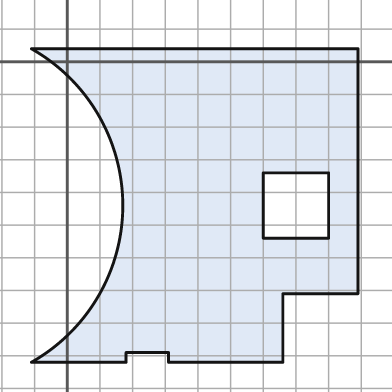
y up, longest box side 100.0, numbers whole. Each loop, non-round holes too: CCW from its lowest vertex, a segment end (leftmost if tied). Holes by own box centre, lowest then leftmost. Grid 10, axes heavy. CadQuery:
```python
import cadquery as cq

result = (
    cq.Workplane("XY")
    .moveTo(-11.0, -92.0)
    .lineTo(18.0, -92.0)
    .lineTo(18.0, -89.0)
    .lineTo(31.0, -89.0)
    .lineTo(31.0, -92.0)
    .lineTo(66.0, -92.0)
    .lineTo(66.0, -71.0)
    .lineTo(89.0, -71.0)
    .lineTo(89.0, 4.0)
    .lineTo(-11.0, 4.0)
    .threePointArc((17.0, -44.0), (-11.0, -92.0))
    .close()
    .moveTo(60.0, -54.0)
    .lineTo(80.0, -54.0)
    .lineTo(80.0, -34.0)
    .lineTo(60.0, -34.0)
    .close()
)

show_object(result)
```